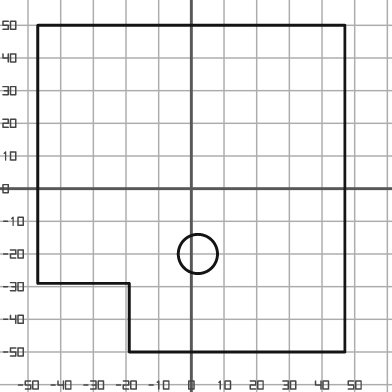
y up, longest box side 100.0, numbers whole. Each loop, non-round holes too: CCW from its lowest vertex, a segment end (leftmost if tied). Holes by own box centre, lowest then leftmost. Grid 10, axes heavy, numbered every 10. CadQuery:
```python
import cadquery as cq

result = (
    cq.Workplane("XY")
    .moveTo(-19.0, -50.0)
    .lineTo(47.0, -50.0)
    .lineTo(47.0, 50.0)
    .lineTo(-47.0, 50.0)
    .lineTo(-47.0, -29.0)
    .lineTo(-19.0, -29.0)
    .close()
    .moveTo(2.0, -20.0)
    .circle(6.0)
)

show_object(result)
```